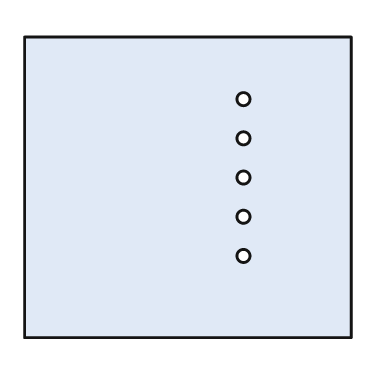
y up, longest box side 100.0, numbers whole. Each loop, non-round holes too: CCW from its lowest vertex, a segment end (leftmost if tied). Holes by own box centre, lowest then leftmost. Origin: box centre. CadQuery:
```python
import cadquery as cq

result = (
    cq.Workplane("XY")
    .moveTo(-50.0, -46.0)
    .lineTo(50.0, -46.0)
    .lineTo(50.0, 46.0)
    .lineTo(-50.0, 46.0)
    .close()
    .moveTo(17.0, -21.0)
    .circle(2.0)
    .moveTo(17.0, -9.0)
    .circle(2.0)
    .moveTo(17.0, 3.0)
    .circle(2.0)
    .moveTo(17.0, 15.0)
    .circle(2.0)
    .moveTo(17.0, 27.0)
    .circle(2.0)
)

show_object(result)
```